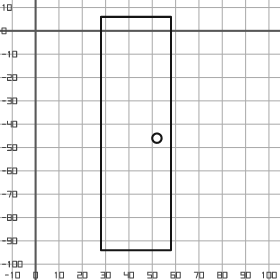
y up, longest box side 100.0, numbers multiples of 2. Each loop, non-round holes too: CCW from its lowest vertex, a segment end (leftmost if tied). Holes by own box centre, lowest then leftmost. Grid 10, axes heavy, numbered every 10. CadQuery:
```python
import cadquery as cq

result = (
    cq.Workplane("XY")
    .moveTo(28.0, -94.0)
    .lineTo(58.0, -94.0)
    .lineTo(58.0, 6.0)
    .lineTo(28.0, 6.0)
    .close()
    .moveTo(52.0, -46.0)
    .circle(2.0)
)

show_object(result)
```